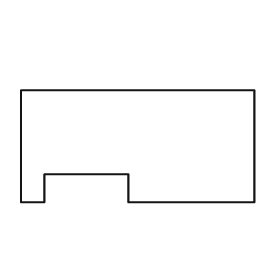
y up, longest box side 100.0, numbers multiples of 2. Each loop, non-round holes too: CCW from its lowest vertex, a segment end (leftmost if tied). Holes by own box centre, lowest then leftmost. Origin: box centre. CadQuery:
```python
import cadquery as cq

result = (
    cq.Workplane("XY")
    .moveTo(-50.0, -24.0)
    .lineTo(-40.0, -24.0)
    .lineTo(-40.0, -12.0)
    .lineTo(-4.0, -12.0)
    .lineTo(-4.0, -24.0)
    .lineTo(50.0, -24.0)
    .lineTo(50.0, 24.0)
    .lineTo(-50.0, 24.0)
    .close()
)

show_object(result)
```